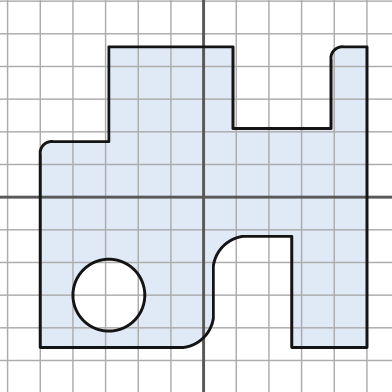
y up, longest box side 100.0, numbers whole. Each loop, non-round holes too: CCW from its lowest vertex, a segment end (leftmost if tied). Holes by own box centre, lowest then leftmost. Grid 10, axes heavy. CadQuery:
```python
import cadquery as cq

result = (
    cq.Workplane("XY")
    .moveTo(-50.0, -46.0)
    .lineTo(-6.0, -46.0)
    .threePointArc((0.0, -43.0), (3.0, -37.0))
    .lineTo(3.0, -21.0)
    .threePointArc((6.0, -15.0), (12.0, -12.0))
    .lineTo(27.0, -12.0)
    .lineTo(27.0, -46.0)
    .lineTo(50.0, -46.0)
    .lineTo(50.0, 46.0)
    .lineTo(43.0, 46.0)
    .threePointArc((40.0, 45.0), (39.0, 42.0))
    .lineTo(39.0, 21.0)
    .lineTo(9.0, 21.0)
    .lineTo(9.0, 46.0)
    .lineTo(-29.0, 46.0)
    .lineTo(-29.0, 17.0)
    .lineTo(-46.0, 17.0)
    .threePointArc((-49.0, 16.0), (-50.0, 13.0))
    .close()
    .moveTo(-29.0, -30.0)
    .circle(11.0)
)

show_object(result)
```